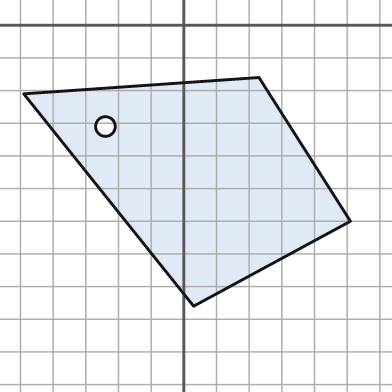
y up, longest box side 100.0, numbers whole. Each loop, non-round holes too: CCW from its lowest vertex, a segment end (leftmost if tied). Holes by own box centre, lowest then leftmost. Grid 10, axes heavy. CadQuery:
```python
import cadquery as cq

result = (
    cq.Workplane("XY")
    .moveTo(3.0, -86.0)
    .lineTo(51.0, -60.0)
    .lineTo(23.0, -16.0)
    .lineTo(-49.0, -21.0)
    .close()
    .moveTo(-24.0, -31.0)
    .circle(3.0)
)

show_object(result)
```